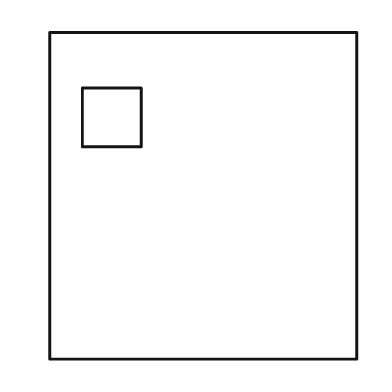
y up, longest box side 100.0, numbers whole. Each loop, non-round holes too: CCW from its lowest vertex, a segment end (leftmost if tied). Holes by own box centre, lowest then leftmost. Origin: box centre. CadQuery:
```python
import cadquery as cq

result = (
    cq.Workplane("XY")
    .moveTo(-47.0, -50.0)
    .lineTo(47.0, -50.0)
    .lineTo(47.0, 50.0)
    .lineTo(-47.0, 50.0)
    .close()
    .moveTo(-37.0, 15.0)
    .lineTo(-19.0, 15.0)
    .lineTo(-19.0, 33.0)
    .lineTo(-37.0, 33.0)
    .close()
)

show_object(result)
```